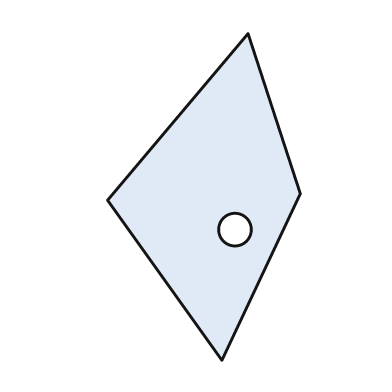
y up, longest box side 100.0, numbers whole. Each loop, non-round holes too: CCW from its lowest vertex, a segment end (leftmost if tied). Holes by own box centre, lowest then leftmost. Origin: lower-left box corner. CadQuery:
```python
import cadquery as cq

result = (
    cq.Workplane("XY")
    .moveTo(35.0, 0.0)
    .lineTo(59.0, 51.0)
    .lineTo(43.0, 100.0)
    .lineTo(0.0, 49.0)
    .close()
    .moveTo(39.0, 40.0)
    .circle(5.0)
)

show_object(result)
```